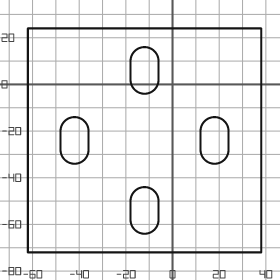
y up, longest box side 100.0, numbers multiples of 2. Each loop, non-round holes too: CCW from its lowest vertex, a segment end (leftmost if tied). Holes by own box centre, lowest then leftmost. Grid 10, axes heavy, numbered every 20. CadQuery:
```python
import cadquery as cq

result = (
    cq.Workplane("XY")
    .moveTo(-62.0, -72.0)
    .lineTo(38.0, -72.0)
    .lineTo(38.0, 24.0)
    .lineTo(-62.0, 24.0)
    .close()
    .moveTo(-18.0, -58.0)
    .threePointArc((-12.0, -64.0), (-6.0, -58.0))
    .lineTo(-6.0, -50.0)
    .threePointArc((-12.0, -44.0), (-18.0, -50.0))
    .close()
    .moveTo(-48.0, -28.0)
    .threePointArc((-42.0, -34.0), (-36.0, -28.0))
    .lineTo(-36.0, -20.0)
    .threePointArc((-42.0, -14.0), (-48.0, -20.0))
    .close()
    .moveTo(12.0, -28.0)
    .threePointArc((18.0, -34.0), (24.0, -28.0))
    .lineTo(24.0, -20.0)
    .threePointArc((18.0, -14.0), (12.0, -20.0))
    .close()
    .moveTo(-18.0, 2.0)
    .threePointArc((-12.0, -4.0), (-6.0, 2.0))
    .lineTo(-6.0, 10.0)
    .threePointArc((-12.0, 16.0), (-18.0, 10.0))
    .close()
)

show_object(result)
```